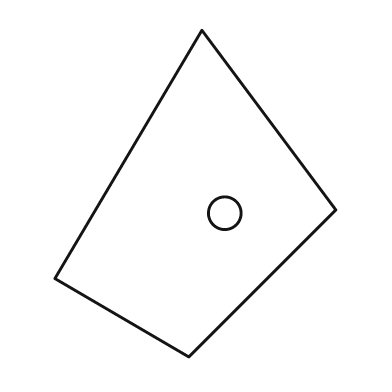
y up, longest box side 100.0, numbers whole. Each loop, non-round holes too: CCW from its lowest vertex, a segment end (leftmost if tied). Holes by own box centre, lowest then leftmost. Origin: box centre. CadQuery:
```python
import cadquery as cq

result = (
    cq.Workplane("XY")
    .moveTo(-2.0, -50.0)
    .lineTo(43.0, -5.0)
    .lineTo(2.0, 50.0)
    .lineTo(-43.0, -26.0)
    .close()
    .moveTo(9.0, -6.0)
    .circle(5.0)
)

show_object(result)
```